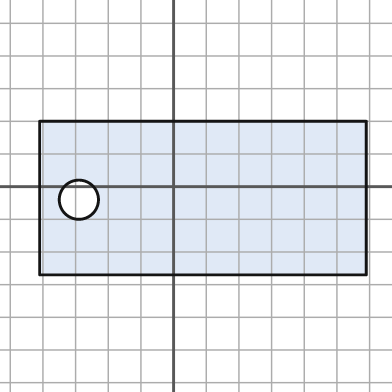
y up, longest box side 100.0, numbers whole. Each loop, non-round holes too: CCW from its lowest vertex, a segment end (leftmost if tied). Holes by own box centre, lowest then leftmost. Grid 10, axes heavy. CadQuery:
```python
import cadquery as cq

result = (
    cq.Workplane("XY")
    .moveTo(-41.0, -27.0)
    .lineTo(59.0, -27.0)
    .lineTo(59.0, 20.0)
    .lineTo(-41.0, 20.0)
    .close()
    .moveTo(-29.0, -4.0)
    .circle(6.0)
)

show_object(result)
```